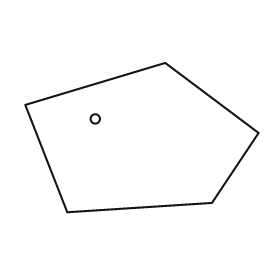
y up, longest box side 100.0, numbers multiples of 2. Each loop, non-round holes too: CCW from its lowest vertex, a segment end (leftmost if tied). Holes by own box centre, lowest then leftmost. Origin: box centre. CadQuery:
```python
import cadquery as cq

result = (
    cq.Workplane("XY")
    .moveTo(-32.0, -32.0)
    .lineTo(30.0, -28.0)
    .lineTo(50.0, 2.0)
    .lineTo(10.0, 32.0)
    .lineTo(-50.0, 14.0)
    .close()
    .moveTo(-20.0, 8.0)
    .circle(2.0)
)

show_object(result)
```